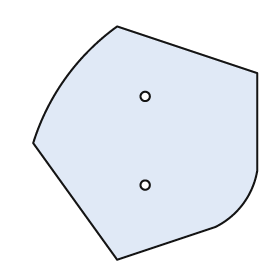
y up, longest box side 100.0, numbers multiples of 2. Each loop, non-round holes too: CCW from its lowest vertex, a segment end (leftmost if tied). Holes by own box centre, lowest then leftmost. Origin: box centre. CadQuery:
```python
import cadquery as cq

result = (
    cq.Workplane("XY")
    .moveTo(-12.0, -50.0)
    .lineTo(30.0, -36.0)
    .threePointArc((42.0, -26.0), (48.0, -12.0))
    .lineTo(48.0, 30.0)
    .lineTo(-12.0, 50.0)
    .threePointArc((-34.0, 28.0), (-48.0, 0.0))
    .close()
    .moveTo(0.0, -18.0)
    .circle(2.0)
    .moveTo(0.0, 20.0)
    .circle(2.0)
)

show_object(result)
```